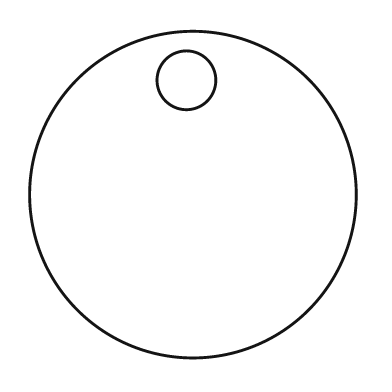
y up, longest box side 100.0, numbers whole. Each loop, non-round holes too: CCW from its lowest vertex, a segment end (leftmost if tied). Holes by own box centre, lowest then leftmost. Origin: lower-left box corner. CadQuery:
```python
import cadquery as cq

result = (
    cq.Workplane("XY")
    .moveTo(50.0, 50.0)
    .circle(50.0)
    .moveTo(48.0, 85.0)
    .circle(9.0)
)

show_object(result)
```